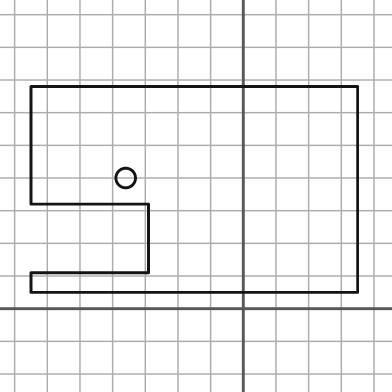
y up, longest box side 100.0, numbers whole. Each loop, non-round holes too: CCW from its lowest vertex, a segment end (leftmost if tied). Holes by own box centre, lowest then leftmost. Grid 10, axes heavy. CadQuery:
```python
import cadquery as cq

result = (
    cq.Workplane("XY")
    .moveTo(-65.0, 5.0)
    .lineTo(35.0, 5.0)
    .lineTo(35.0, 68.0)
    .lineTo(-65.0, 68.0)
    .lineTo(-65.0, 32.0)
    .lineTo(-29.0, 32.0)
    .lineTo(-29.0, 11.0)
    .lineTo(-65.0, 11.0)
    .close()
    .moveTo(-36.0, 40.0)
    .circle(3.0)
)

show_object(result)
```